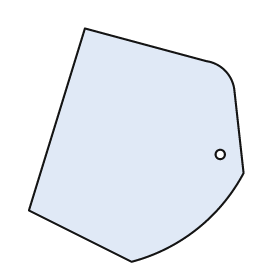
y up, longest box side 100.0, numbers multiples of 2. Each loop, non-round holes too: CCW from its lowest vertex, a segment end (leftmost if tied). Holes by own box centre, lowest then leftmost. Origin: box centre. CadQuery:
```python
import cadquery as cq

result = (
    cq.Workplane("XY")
    .moveTo(-2.0, -50.0)
    .threePointArc((26.0, -36.0), (46.0, -12.0))
    .lineTo(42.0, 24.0)
    .threePointArc((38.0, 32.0), (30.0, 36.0))
    .lineTo(-22.0, 50.0)
    .lineTo(-46.0, -28.0)
    .close()
    .moveTo(36.0, -4.0)
    .circle(2.0)
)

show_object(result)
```